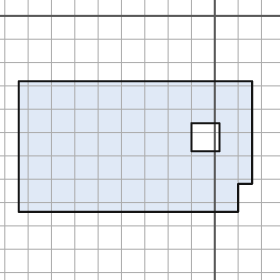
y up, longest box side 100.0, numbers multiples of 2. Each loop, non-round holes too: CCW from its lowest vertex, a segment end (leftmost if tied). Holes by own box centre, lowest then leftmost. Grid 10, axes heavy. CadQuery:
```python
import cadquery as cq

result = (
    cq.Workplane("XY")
    .moveTo(-84.0, -84.0)
    .lineTo(10.0, -84.0)
    .lineTo(10.0, -72.0)
    .lineTo(16.0, -72.0)
    .lineTo(16.0, -28.0)
    .lineTo(-84.0, -28.0)
    .close()
    .moveTo(-10.0, -58.0)
    .lineTo(2.0, -58.0)
    .lineTo(2.0, -46.0)
    .lineTo(-10.0, -46.0)
    .close()
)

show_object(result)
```